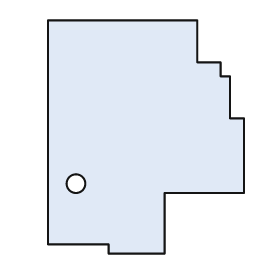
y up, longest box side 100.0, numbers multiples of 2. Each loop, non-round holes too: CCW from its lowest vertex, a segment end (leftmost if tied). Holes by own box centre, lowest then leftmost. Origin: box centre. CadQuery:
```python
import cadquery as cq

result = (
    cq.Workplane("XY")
    .moveTo(-16.0, -50.0)
    .lineTo(8.0, -50.0)
    .lineTo(8.0, -24.0)
    .lineTo(42.0, -24.0)
    .lineTo(42.0, 8.0)
    .lineTo(36.0, 8.0)
    .lineTo(36.0, 26.0)
    .lineTo(32.0, 26.0)
    .lineTo(32.0, 32.0)
    .lineTo(22.0, 32.0)
    .lineTo(22.0, 50.0)
    .lineTo(-42.0, 50.0)
    .lineTo(-42.0, -46.0)
    .lineTo(-16.0, -46.0)
    .close()
    .moveTo(-30.0, -20.0)
    .circle(4.0)
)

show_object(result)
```